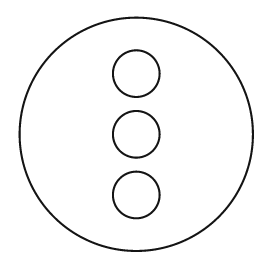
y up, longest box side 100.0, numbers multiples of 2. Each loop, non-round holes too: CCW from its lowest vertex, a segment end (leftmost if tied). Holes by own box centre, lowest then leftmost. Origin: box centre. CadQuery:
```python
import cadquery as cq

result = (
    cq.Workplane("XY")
    .moveTo(0.0, 0.0)
    .circle(50.0)
    .moveTo(0.0, -26.0)
    .circle(10.0)
    .moveTo(0.0, 0.0)
    .circle(10.0)
    .moveTo(0.0, 26.0)
    .circle(10.0)
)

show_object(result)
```